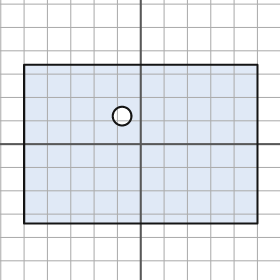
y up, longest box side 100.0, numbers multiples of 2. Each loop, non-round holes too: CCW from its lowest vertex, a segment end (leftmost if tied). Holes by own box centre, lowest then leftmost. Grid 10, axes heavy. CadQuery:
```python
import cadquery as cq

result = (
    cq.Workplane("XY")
    .moveTo(-50.0, -34.0)
    .lineTo(50.0, -34.0)
    .lineTo(50.0, 34.0)
    .lineTo(-50.0, 34.0)
    .close()
    .moveTo(-8.0, 12.0)
    .circle(4.0)
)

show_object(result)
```